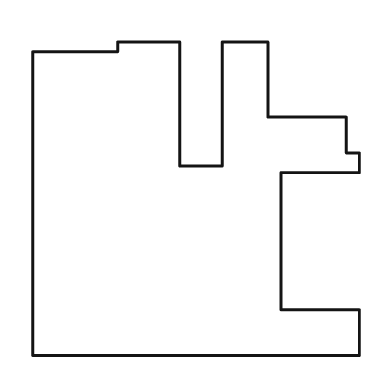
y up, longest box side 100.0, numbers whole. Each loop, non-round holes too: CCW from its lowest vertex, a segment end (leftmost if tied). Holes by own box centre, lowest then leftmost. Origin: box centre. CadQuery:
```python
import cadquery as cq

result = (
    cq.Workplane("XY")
    .moveTo(-50.0, -48.0)
    .lineTo(50.0, -48.0)
    .lineTo(50.0, -34.0)
    .lineTo(26.0, -34.0)
    .lineTo(26.0, 8.0)
    .lineTo(50.0, 8.0)
    .lineTo(50.0, 14.0)
    .lineTo(46.0, 14.0)
    .lineTo(46.0, 25.0)
    .lineTo(22.0, 25.0)
    .lineTo(22.0, 48.0)
    .lineTo(8.0, 48.0)
    .lineTo(8.0, 10.0)
    .lineTo(-5.0, 10.0)
    .lineTo(-5.0, 48.0)
    .lineTo(-24.0, 48.0)
    .lineTo(-24.0, 45.0)
    .lineTo(-50.0, 45.0)
    .close()
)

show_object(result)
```